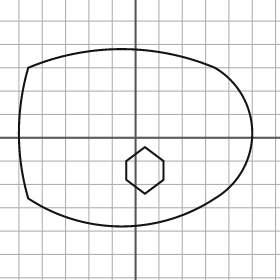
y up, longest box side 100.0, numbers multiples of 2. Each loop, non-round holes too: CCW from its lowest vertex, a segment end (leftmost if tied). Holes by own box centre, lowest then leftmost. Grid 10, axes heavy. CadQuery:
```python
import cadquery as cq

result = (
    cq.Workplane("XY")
    .moveTo(-46.0, -26.0)
    .threePointArc((-6.0, -38.0), (34.0, -26.0))
    .threePointArc((50.0, 2.0), (34.0, 30.0))
    .threePointArc((-6.0, 38.0), (-46.0, 30.0))
    .threePointArc((-50.0, 2.0), (-46.0, -26.0))
    .close()
    .moveTo(4.0, -24.0)
    .lineTo(12.0, -18.0)
    .lineTo(12.0, -10.0)
    .lineTo(4.0, -4.0)
    .lineTo(-4.0, -10.0)
    .lineTo(-4.0, -18.0)
    .close()
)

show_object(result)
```